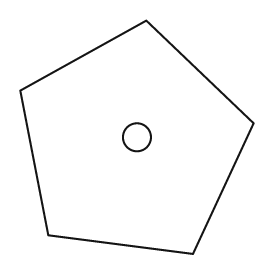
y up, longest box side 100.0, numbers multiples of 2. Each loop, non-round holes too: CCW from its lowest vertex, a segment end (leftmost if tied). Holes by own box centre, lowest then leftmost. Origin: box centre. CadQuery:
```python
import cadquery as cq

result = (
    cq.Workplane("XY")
    .moveTo(24.0, -50.0)
    .lineTo(50.0, 6.0)
    .lineTo(4.0, 50.0)
    .lineTo(-50.0, 20.0)
    .lineTo(-38.0, -42.0)
    .close()
    .moveTo(0.0, 0.0)
    .circle(6.0)
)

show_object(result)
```